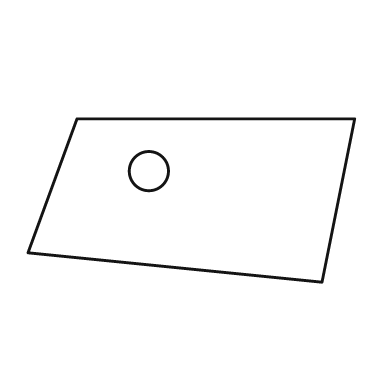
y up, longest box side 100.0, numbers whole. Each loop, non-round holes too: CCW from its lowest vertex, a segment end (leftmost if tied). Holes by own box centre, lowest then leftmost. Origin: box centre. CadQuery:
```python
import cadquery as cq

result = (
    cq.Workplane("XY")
    .moveTo(40.0, -25.0)
    .lineTo(50.0, 25.0)
    .lineTo(-35.0, 25.0)
    .lineTo(-50.0, -16.0)
    .close()
    .moveTo(-13.0, 9.0)
    .circle(6.0)
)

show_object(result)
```